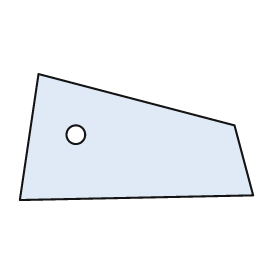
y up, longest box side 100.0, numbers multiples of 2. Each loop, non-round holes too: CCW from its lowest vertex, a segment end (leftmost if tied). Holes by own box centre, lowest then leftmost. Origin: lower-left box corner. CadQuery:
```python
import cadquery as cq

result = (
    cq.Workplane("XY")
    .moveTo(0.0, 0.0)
    .lineTo(100.0, 2.0)
    .lineTo(92.0, 32.0)
    .lineTo(8.0, 54.0)
    .close()
    .moveTo(24.0, 28.0)
    .circle(4.0)
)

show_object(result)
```